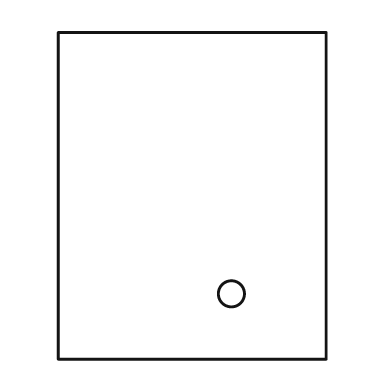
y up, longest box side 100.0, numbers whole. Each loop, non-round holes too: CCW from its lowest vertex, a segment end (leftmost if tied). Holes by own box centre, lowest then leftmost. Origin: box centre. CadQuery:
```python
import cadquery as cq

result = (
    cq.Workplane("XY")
    .moveTo(-41.0, -50.0)
    .lineTo(41.0, -50.0)
    .lineTo(41.0, 50.0)
    .lineTo(-41.0, 50.0)
    .close()
    .moveTo(12.0, -30.0)
    .circle(4.0)
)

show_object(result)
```